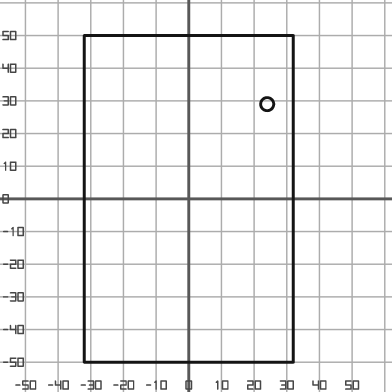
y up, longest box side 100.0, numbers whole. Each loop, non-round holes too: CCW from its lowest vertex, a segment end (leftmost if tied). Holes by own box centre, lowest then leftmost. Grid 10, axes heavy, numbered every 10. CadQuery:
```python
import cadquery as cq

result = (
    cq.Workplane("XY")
    .moveTo(-32.0, -50.0)
    .lineTo(32.0, -50.0)
    .lineTo(32.0, 50.0)
    .lineTo(-32.0, 50.0)
    .close()
    .moveTo(24.0, 29.0)
    .circle(2.0)
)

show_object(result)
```